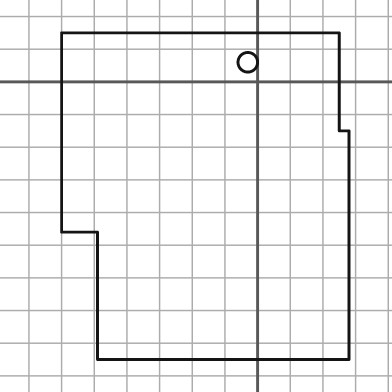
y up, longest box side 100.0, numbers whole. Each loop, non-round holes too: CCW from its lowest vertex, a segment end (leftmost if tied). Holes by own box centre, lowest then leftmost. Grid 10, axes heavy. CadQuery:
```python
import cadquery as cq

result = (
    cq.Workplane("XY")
    .moveTo(-49.0, -85.0)
    .lineTo(28.0, -85.0)
    .lineTo(28.0, -15.0)
    .lineTo(25.0, -15.0)
    .lineTo(25.0, 15.0)
    .lineTo(-60.0, 15.0)
    .lineTo(-60.0, -46.0)
    .lineTo(-49.0, -46.0)
    .close()
    .moveTo(-3.0, 6.0)
    .circle(3.0)
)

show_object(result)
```